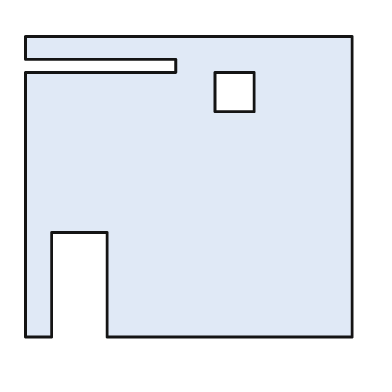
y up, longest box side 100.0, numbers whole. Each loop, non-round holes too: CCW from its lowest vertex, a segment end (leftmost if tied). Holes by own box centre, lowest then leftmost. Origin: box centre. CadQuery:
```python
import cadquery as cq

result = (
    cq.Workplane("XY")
    .moveTo(-50.0, -46.0)
    .lineTo(-42.0, -46.0)
    .lineTo(-42.0, -14.0)
    .lineTo(-25.0, -14.0)
    .lineTo(-25.0, -46.0)
    .lineTo(50.0, -46.0)
    .lineTo(50.0, 46.0)
    .lineTo(-50.0, 46.0)
    .lineTo(-50.0, 39.0)
    .lineTo(-4.0, 39.0)
    .lineTo(-4.0, 35.0)
    .lineTo(-50.0, 35.0)
    .close()
    .moveTo(8.0, 23.0)
    .lineTo(20.0, 23.0)
    .lineTo(20.0, 35.0)
    .lineTo(8.0, 35.0)
    .close()
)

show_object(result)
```